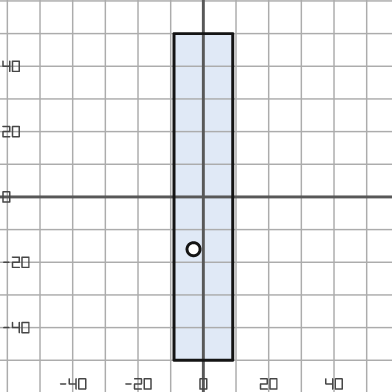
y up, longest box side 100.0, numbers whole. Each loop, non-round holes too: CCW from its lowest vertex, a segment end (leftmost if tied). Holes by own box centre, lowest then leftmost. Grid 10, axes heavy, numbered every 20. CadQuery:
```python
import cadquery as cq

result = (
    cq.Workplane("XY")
    .moveTo(-9.0, -50.0)
    .lineTo(9.0, -50.0)
    .lineTo(9.0, 50.0)
    .lineTo(-9.0, 50.0)
    .close()
    .moveTo(-3.0, -16.0)
    .circle(2.0)
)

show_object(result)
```